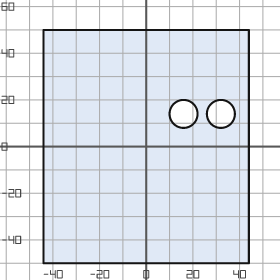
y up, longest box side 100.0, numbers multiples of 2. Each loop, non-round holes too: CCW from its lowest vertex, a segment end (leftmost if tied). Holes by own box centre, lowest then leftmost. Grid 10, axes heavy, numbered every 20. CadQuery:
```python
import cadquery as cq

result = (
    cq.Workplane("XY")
    .moveTo(-44.0, -50.0)
    .lineTo(44.0, -50.0)
    .lineTo(44.0, 50.0)
    .lineTo(-44.0, 50.0)
    .close()
    .moveTo(16.0, 14.0)
    .circle(6.0)
    .moveTo(32.0, 14.0)
    .circle(6.0)
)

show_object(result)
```